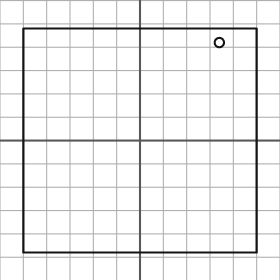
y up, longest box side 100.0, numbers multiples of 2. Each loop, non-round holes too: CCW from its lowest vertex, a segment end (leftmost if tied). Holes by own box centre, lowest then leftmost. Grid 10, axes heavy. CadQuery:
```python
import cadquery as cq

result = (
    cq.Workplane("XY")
    .moveTo(-50.0, -48.0)
    .lineTo(50.0, -48.0)
    .lineTo(50.0, 48.0)
    .lineTo(-50.0, 48.0)
    .close()
    .moveTo(34.0, 42.0)
    .circle(2.0)
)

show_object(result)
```